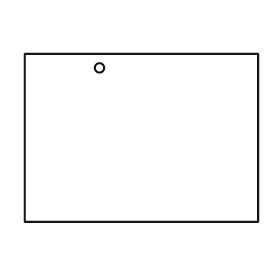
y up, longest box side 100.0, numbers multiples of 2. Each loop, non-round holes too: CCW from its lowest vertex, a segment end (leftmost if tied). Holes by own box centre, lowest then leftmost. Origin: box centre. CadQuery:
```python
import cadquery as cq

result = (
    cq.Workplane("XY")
    .moveTo(-50.0, -36.0)
    .lineTo(50.0, -36.0)
    .lineTo(50.0, 36.0)
    .lineTo(-50.0, 36.0)
    .close()
    .moveTo(-18.0, 30.0)
    .circle(2.0)
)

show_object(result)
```